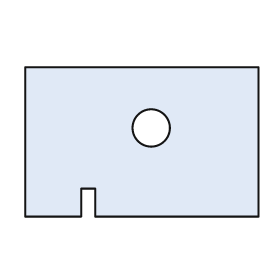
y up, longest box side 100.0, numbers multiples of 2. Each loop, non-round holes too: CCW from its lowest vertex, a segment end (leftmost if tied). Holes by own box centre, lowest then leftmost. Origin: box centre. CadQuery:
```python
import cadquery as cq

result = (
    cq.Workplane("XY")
    .moveTo(-50.0, -32.0)
    .lineTo(-26.0, -32.0)
    .lineTo(-26.0, -20.0)
    .lineTo(-20.0, -20.0)
    .lineTo(-20.0, -32.0)
    .lineTo(50.0, -32.0)
    .lineTo(50.0, 32.0)
    .lineTo(-50.0, 32.0)
    .close()
    .moveTo(4.0, 6.0)
    .circle(8.0)
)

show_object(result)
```